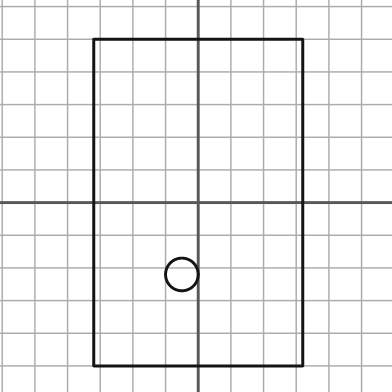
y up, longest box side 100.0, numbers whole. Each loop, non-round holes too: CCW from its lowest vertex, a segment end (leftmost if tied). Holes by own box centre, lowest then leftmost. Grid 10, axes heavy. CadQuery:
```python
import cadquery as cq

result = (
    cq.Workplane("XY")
    .moveTo(-32.0, -50.0)
    .lineTo(32.0, -50.0)
    .lineTo(32.0, 50.0)
    .lineTo(-32.0, 50.0)
    .close()
    .moveTo(-5.0, -22.0)
    .circle(5.0)
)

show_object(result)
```